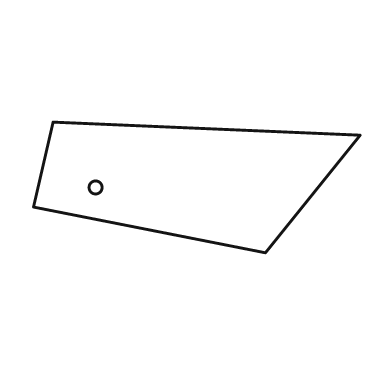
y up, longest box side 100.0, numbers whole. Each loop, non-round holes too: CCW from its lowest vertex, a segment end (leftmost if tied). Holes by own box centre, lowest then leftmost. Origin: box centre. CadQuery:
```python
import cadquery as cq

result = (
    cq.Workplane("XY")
    .moveTo(21.0, -20.0)
    .lineTo(50.0, 16.0)
    .lineTo(-44.0, 20.0)
    .lineTo(-50.0, -6.0)
    .close()
    .moveTo(-31.0, 0.0)
    .circle(2.0)
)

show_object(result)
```